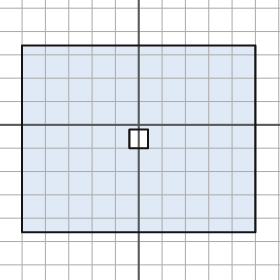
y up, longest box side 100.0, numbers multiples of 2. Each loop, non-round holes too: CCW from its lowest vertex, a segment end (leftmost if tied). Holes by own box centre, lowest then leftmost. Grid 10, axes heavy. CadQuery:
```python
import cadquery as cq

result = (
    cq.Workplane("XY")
    .moveTo(-50.0, -46.0)
    .lineTo(50.0, -46.0)
    .lineTo(50.0, 34.0)
    .lineTo(-50.0, 34.0)
    .close()
    .moveTo(-4.0, -10.0)
    .lineTo(4.0, -10.0)
    .lineTo(4.0, -2.0)
    .lineTo(-4.0, -2.0)
    .close()
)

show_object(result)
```